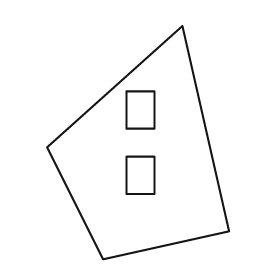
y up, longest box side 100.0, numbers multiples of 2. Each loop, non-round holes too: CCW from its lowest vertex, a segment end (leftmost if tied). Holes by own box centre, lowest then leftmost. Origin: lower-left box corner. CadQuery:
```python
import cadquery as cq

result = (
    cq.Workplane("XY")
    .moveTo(24.0, 0.0)
    .lineTo(78.0, 12.0)
    .lineTo(58.0, 100.0)
    .lineTo(0.0, 48.0)
    .close()
    .moveTo(34.0, 28.0)
    .lineTo(46.0, 28.0)
    .lineTo(46.0, 44.0)
    .lineTo(34.0, 44.0)
    .close()
    .moveTo(34.0, 56.0)
    .lineTo(46.0, 56.0)
    .lineTo(46.0, 72.0)
    .lineTo(34.0, 72.0)
    .close()
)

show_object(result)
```